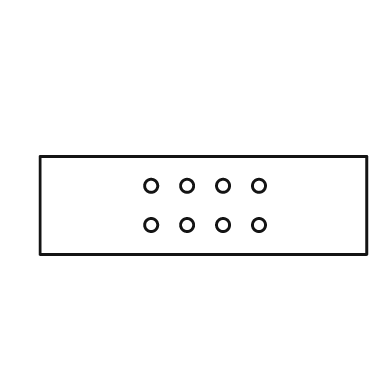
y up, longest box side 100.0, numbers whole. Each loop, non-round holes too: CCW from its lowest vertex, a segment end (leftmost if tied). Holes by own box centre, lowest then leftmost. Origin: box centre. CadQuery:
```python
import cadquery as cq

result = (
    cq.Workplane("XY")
    .moveTo(-50.0, -15.0)
    .lineTo(50.0, -15.0)
    .lineTo(50.0, 15.0)
    .lineTo(-50.0, 15.0)
    .close()
    .moveTo(-16.0, -6.0)
    .circle(2.0)
    .moveTo(-5.0, -6.0)
    .circle(2.0)
    .moveTo(6.0, -6.0)
    .circle(2.0)
    .moveTo(17.0, -6.0)
    .circle(2.0)
    .moveTo(-16.0, 6.0)
    .circle(2.0)
    .moveTo(-5.0, 6.0)
    .circle(2.0)
    .moveTo(6.0, 6.0)
    .circle(2.0)
    .moveTo(17.0, 6.0)
    .circle(2.0)
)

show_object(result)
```